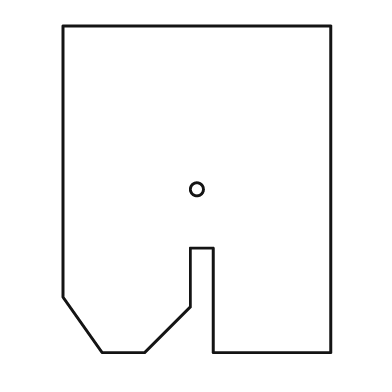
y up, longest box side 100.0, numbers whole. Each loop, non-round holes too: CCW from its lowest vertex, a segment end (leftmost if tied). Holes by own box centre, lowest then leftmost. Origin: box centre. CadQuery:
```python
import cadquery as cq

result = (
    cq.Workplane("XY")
    .moveTo(-29.0, -50.0)
    .lineTo(-16.0, -50.0)
    .lineTo(-2.0, -36.0)
    .lineTo(-2.0, -18.0)
    .lineTo(5.0, -18.0)
    .lineTo(5.0, -50.0)
    .lineTo(41.0, -50.0)
    .lineTo(41.0, 50.0)
    .lineTo(-41.0, 50.0)
    .lineTo(-41.0, -33.0)
    .close()
    .moveTo(0.0, 0.0)
    .circle(2.0)
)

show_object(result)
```